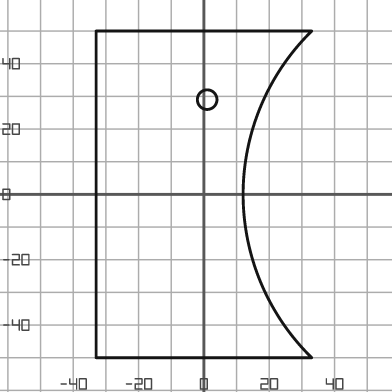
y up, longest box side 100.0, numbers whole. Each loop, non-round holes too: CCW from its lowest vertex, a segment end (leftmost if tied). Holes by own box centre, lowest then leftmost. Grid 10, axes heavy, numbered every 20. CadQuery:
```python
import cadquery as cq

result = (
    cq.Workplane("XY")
    .moveTo(-33.0, -50.0)
    .lineTo(33.0, -50.0)
    .threePointArc((12.0, 0.0), (33.0, 50.0))
    .lineTo(-33.0, 50.0)
    .close()
    .moveTo(1.0, 29.0)
    .circle(3.0)
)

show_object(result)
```